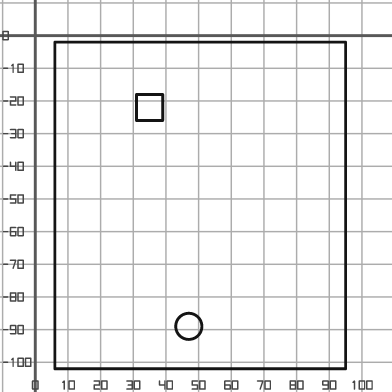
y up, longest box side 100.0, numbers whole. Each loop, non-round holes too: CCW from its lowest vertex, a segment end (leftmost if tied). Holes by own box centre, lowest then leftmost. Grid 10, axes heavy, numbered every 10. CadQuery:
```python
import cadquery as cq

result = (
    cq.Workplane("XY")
    .moveTo(6.0, -102.0)
    .lineTo(95.0, -102.0)
    .lineTo(95.0, -2.0)
    .lineTo(6.0, -2.0)
    .close()
    .moveTo(47.0, -89.0)
    .circle(4.0)
    .moveTo(31.0, -26.0)
    .lineTo(39.0, -26.0)
    .lineTo(39.0, -18.0)
    .lineTo(31.0, -18.0)
    .close()
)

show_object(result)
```